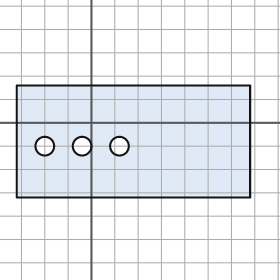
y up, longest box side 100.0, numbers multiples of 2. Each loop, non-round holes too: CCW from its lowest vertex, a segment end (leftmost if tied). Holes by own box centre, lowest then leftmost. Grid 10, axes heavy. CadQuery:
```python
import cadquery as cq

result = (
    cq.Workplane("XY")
    .moveTo(-32.0, -32.0)
    .lineTo(68.0, -32.0)
    .lineTo(68.0, 16.0)
    .lineTo(-32.0, 16.0)
    .close()
    .moveTo(-20.0, -10.0)
    .circle(4.0)
    .moveTo(-4.0, -10.0)
    .circle(4.0)
    .moveTo(12.0, -10.0)
    .circle(4.0)
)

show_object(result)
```